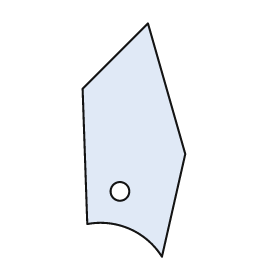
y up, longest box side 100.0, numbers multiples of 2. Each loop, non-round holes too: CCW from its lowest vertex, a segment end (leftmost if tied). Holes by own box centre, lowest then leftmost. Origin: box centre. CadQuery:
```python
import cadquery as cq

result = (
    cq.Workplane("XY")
    .moveTo(12.0, -50.0)
    .lineTo(22.0, -6.0)
    .lineTo(6.0, 50.0)
    .lineTo(-22.0, 22.0)
    .lineTo(-20.0, -36.0)
    .threePointArc((-2.0, -38.0), (12.0, -50.0))
    .close()
    .moveTo(-6.0, -22.0)
    .circle(4.0)
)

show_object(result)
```